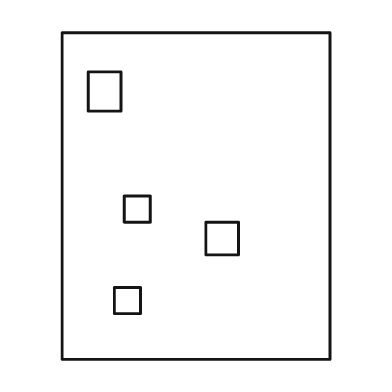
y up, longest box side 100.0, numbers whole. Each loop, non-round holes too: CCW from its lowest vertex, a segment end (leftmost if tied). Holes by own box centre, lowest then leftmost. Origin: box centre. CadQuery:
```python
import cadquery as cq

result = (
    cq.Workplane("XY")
    .moveTo(-41.0, -50.0)
    .lineTo(41.0, -50.0)
    .lineTo(41.0, 50.0)
    .lineTo(-41.0, 50.0)
    .close()
    .moveTo(-25.0, -36.0)
    .lineTo(-17.0, -36.0)
    .lineTo(-17.0, -28.0)
    .lineTo(-25.0, -28.0)
    .close()
    .moveTo(3.0, -18.0)
    .lineTo(13.0, -18.0)
    .lineTo(13.0, -8.0)
    .lineTo(3.0, -8.0)
    .close()
    .moveTo(-22.0, -8.0)
    .lineTo(-14.0, -8.0)
    .lineTo(-14.0, 0.0)
    .lineTo(-22.0, 0.0)
    .close()
    .moveTo(-33.0, 26.0)
    .lineTo(-23.0, 26.0)
    .lineTo(-23.0, 38.0)
    .lineTo(-33.0, 38.0)
    .close()
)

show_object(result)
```